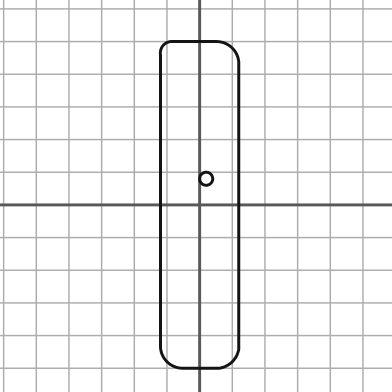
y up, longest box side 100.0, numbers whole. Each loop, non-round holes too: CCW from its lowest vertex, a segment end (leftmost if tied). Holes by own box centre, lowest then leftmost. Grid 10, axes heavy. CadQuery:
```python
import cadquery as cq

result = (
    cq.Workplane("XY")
    .moveTo(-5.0, -50.0)
    .lineTo(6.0, -50.0)
    .threePointArc((10.0, -48.0), (12.0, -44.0))
    .lineTo(12.0, 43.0)
    .threePointArc((10.0, 48.0), (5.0, 50.0))
    .lineTo(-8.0, 50.0)
    .threePointArc((-11.0, 49.0), (-12.0, 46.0))
    .lineTo(-12.0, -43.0)
    .threePointArc((-10.0, -48.0), (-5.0, -50.0))
    .close()
    .moveTo(2.0, 8.0)
    .circle(2.0)
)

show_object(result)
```